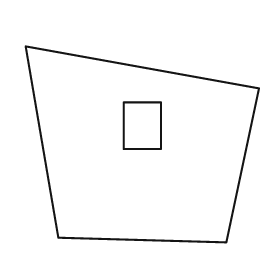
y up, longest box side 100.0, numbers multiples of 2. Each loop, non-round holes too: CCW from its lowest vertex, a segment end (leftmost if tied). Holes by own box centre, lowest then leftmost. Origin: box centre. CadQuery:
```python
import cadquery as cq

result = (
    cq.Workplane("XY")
    .moveTo(36.0, -42.0)
    .lineTo(50.0, 24.0)
    .lineTo(-50.0, 42.0)
    .lineTo(-36.0, -40.0)
    .close()
    .moveTo(-8.0, -2.0)
    .lineTo(8.0, -2.0)
    .lineTo(8.0, 18.0)
    .lineTo(-8.0, 18.0)
    .close()
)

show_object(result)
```